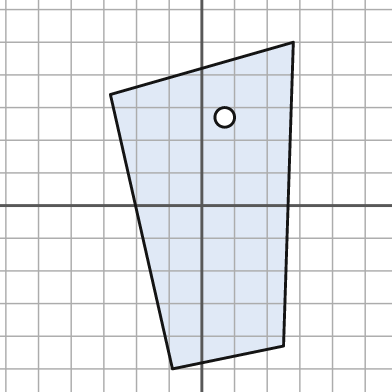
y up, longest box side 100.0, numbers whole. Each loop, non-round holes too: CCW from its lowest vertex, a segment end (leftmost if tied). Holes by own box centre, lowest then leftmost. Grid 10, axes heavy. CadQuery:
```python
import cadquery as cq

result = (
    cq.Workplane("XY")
    .moveTo(-9.0, -50.0)
    .lineTo(25.0, -43.0)
    .lineTo(28.0, 50.0)
    .lineTo(-28.0, 34.0)
    .close()
    .moveTo(7.0, 27.0)
    .circle(3.0)
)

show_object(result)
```